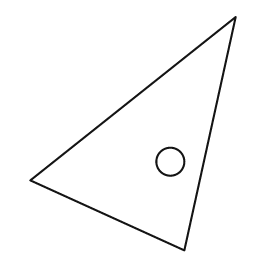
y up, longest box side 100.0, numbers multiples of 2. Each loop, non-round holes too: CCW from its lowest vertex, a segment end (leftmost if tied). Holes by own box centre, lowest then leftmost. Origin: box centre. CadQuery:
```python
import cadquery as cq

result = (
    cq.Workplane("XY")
    .moveTo(22.0, -50.0)
    .lineTo(44.0, 50.0)
    .lineTo(-44.0, -20.0)
    .close()
    .moveTo(16.0, -12.0)
    .circle(6.0)
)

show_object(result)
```